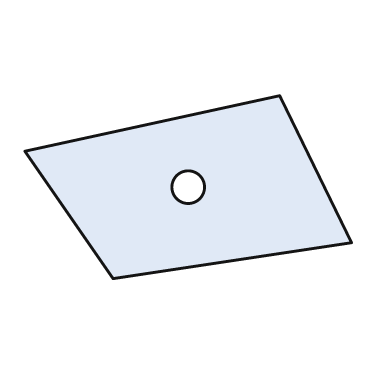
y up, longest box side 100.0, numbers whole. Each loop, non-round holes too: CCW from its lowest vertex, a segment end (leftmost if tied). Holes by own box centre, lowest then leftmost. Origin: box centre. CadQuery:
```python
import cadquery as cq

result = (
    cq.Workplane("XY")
    .moveTo(-23.0, -28.0)
    .lineTo(50.0, -17.0)
    .lineTo(28.0, 28.0)
    .lineTo(-50.0, 11.0)
    .close()
    .moveTo(0.0, 0.0)
    .circle(5.0)
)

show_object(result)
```